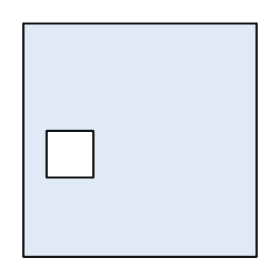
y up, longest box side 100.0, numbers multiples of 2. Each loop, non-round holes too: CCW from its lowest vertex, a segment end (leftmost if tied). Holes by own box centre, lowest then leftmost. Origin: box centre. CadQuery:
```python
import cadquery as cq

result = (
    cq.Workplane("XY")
    .moveTo(-50.0, -50.0)
    .lineTo(50.0, -50.0)
    .lineTo(50.0, 50.0)
    .lineTo(-50.0, 50.0)
    .close()
    .moveTo(-40.0, -16.0)
    .lineTo(-20.0, -16.0)
    .lineTo(-20.0, 4.0)
    .lineTo(-40.0, 4.0)
    .close()
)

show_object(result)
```